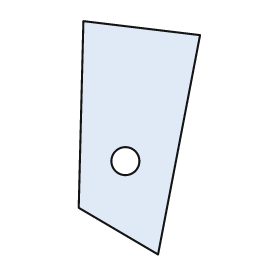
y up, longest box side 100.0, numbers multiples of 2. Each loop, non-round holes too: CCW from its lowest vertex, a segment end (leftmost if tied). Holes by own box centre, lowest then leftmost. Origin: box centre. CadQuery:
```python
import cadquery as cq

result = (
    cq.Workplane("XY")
    .moveTo(8.0, -50.0)
    .lineTo(26.0, 44.0)
    .lineTo(-24.0, 50.0)
    .lineTo(-26.0, -30.0)
    .close()
    .moveTo(-6.0, -10.0)
    .circle(6.0)
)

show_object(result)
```